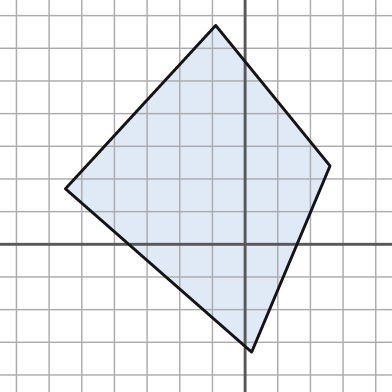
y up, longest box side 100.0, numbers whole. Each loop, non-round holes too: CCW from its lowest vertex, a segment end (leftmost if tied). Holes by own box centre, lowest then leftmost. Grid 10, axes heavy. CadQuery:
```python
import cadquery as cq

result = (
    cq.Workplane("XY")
    .moveTo(2.0, -33.0)
    .lineTo(26.0, 24.0)
    .lineTo(-9.0, 67.0)
    .lineTo(-55.0, 17.0)
    .close()
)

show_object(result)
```